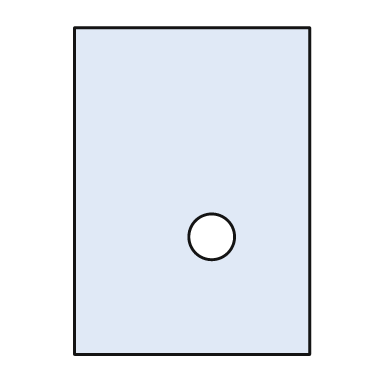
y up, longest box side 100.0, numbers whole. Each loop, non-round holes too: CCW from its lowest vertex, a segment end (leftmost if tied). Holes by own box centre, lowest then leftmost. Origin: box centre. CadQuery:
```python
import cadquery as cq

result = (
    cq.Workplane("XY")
    .moveTo(-36.0, -50.0)
    .lineTo(36.0, -50.0)
    .lineTo(36.0, 50.0)
    .lineTo(-36.0, 50.0)
    .close()
    .moveTo(6.0, -14.0)
    .circle(7.0)
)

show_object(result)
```